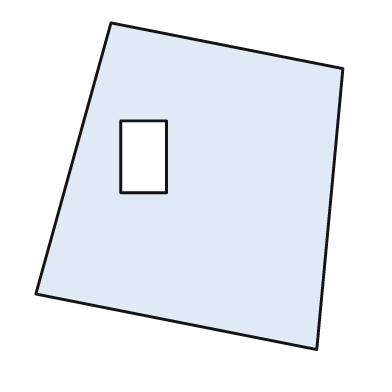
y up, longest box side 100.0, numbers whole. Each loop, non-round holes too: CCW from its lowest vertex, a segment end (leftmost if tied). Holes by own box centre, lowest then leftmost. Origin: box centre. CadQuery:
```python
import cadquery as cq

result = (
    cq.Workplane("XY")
    .moveTo(39.0, -50.0)
    .lineTo(47.0, 36.0)
    .lineTo(-24.0, 50.0)
    .lineTo(-47.0, -33.0)
    .close()
    .moveTo(-21.0, -2.0)
    .lineTo(-7.0, -2.0)
    .lineTo(-7.0, 20.0)
    .lineTo(-21.0, 20.0)
    .close()
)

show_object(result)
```